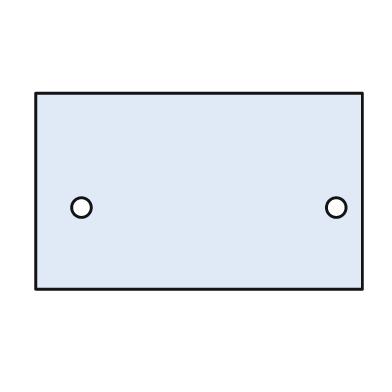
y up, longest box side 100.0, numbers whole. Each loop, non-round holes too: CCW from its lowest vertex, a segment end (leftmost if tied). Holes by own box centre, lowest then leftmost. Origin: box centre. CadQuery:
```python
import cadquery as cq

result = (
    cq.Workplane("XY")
    .moveTo(-50.0, -30.0)
    .lineTo(50.0, -30.0)
    .lineTo(50.0, 30.0)
    .lineTo(-50.0, 30.0)
    .close()
    .moveTo(-36.0, -5.0)
    .circle(3.0)
    .moveTo(42.0, -5.0)
    .circle(3.0)
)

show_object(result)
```